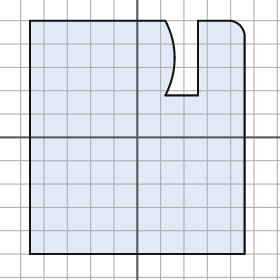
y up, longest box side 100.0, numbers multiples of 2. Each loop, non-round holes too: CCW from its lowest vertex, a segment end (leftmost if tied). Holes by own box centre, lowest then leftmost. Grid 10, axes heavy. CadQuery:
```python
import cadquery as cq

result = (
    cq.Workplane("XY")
    .moveTo(-46.0, -50.0)
    .lineTo(46.0, -50.0)
    .lineTo(46.0, 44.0)
    .threePointArc((44.0, 48.0), (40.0, 50.0))
    .lineTo(26.0, 50.0)
    .lineTo(26.0, 18.0)
    .lineTo(12.0, 18.0)
    .threePointArc((16.0, 34.0), (12.0, 50.0))
    .lineTo(-46.0, 50.0)
    .close()
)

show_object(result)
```